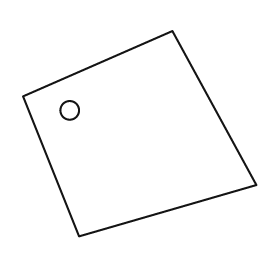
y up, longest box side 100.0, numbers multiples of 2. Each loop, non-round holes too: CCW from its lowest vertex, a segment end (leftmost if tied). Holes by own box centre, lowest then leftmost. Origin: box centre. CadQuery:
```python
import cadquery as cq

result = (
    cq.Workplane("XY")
    .moveTo(-26.0, -44.0)
    .lineTo(50.0, -22.0)
    .lineTo(14.0, 44.0)
    .lineTo(-50.0, 16.0)
    .close()
    .moveTo(-30.0, 10.0)
    .circle(4.0)
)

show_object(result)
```